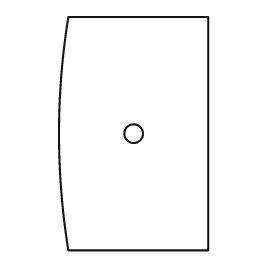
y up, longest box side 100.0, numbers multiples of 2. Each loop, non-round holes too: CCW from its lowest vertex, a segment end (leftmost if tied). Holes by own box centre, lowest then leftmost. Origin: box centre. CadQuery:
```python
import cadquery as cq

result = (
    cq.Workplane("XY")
    .moveTo(-28.0, -50.0)
    .lineTo(32.0, -50.0)
    .lineTo(32.0, 50.0)
    .lineTo(-28.0, 50.0)
    .threePointArc((-32.0, 0.0), (-28.0, -50.0))
    .close()
    .moveTo(0.0, 0.0)
    .circle(4.0)
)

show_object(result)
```